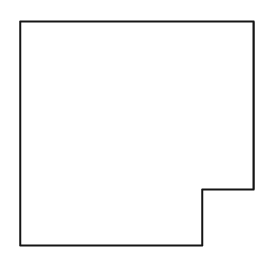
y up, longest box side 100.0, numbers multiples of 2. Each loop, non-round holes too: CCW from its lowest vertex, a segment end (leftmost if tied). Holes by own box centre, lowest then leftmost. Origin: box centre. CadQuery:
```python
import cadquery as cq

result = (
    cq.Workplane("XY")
    .moveTo(-50.0, -48.0)
    .lineTo(28.0, -48.0)
    .lineTo(28.0, -24.0)
    .lineTo(50.0, -24.0)
    .lineTo(50.0, 48.0)
    .lineTo(-50.0, 48.0)
    .close()
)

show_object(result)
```